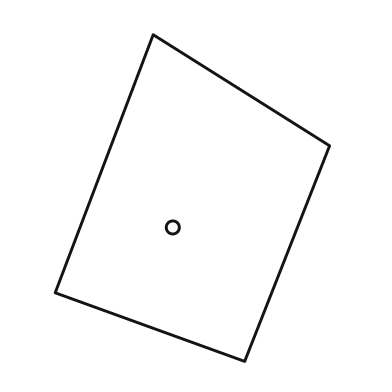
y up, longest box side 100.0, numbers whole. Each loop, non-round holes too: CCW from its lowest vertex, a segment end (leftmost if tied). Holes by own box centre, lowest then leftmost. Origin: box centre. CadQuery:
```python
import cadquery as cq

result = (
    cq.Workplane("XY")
    .moveTo(16.0, -50.0)
    .lineTo(42.0, 16.0)
    .lineTo(-12.0, 50.0)
    .lineTo(-42.0, -29.0)
    .close()
    .moveTo(-6.0, -9.0)
    .circle(2.0)
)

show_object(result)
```